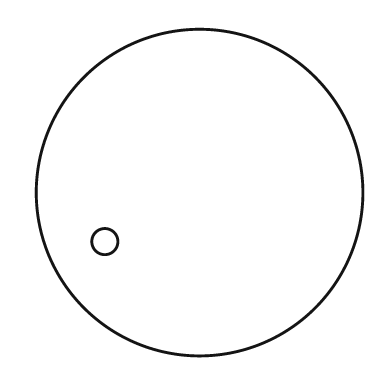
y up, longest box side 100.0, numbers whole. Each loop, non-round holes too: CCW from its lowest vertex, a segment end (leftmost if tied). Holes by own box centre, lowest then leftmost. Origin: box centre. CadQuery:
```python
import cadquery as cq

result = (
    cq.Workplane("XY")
    .moveTo(0.0, 0.0)
    .circle(50.0)
    .moveTo(-29.0, -15.0)
    .circle(4.0)
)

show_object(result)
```